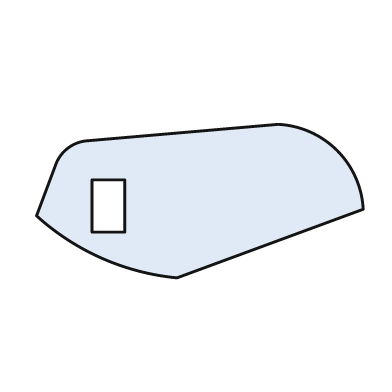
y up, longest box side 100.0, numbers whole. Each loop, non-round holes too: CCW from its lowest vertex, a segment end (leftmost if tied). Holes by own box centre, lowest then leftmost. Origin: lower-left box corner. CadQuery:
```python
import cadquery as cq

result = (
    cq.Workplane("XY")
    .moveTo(43.0, 0.0)
    .lineTo(100.0, 21.0)
    .threePointArc((92.0, 39.0), (74.0, 47.0))
    .lineTo(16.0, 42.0)
    .threePointArc((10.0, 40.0), (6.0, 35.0))
    .lineTo(0.0, 19.0)
    .threePointArc((20.0, 6.0), (43.0, 0.0))
    .close()
    .moveTo(17.0, 14.0)
    .lineTo(27.0, 14.0)
    .lineTo(27.0, 30.0)
    .lineTo(17.0, 30.0)
    .close()
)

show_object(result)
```